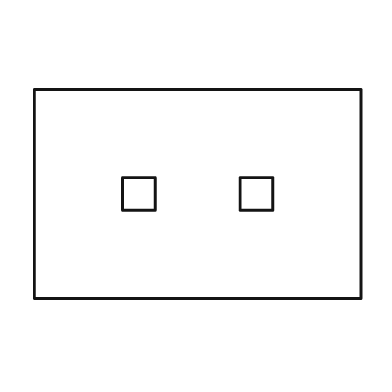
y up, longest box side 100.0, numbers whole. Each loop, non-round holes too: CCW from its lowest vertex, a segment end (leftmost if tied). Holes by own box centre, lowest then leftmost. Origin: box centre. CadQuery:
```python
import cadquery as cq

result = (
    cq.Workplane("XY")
    .moveTo(-50.0, -32.0)
    .lineTo(50.0, -32.0)
    .lineTo(50.0, 32.0)
    .lineTo(-50.0, 32.0)
    .close()
    .moveTo(-23.0, -5.0)
    .lineTo(-13.0, -5.0)
    .lineTo(-13.0, 5.0)
    .lineTo(-23.0, 5.0)
    .close()
    .moveTo(13.0, -5.0)
    .lineTo(23.0, -5.0)
    .lineTo(23.0, 5.0)
    .lineTo(13.0, 5.0)
    .close()
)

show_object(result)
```